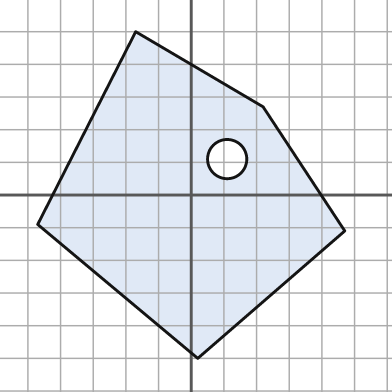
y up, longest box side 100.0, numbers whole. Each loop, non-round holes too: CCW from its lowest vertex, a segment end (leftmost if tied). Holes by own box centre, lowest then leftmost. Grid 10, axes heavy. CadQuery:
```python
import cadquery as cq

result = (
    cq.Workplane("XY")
    .moveTo(2.0, -50.0)
    .lineTo(47.0, -11.0)
    .lineTo(22.0, 27.0)
    .lineTo(-17.0, 50.0)
    .lineTo(-47.0, -9.0)
    .close()
    .moveTo(11.0, 11.0)
    .circle(6.0)
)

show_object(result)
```